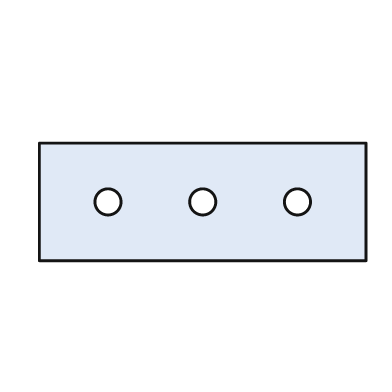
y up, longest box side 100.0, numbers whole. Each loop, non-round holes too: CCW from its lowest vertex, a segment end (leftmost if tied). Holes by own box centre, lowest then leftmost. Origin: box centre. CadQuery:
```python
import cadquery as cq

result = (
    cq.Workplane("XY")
    .moveTo(-50.0, -18.0)
    .lineTo(50.0, -18.0)
    .lineTo(50.0, 18.0)
    .lineTo(-50.0, 18.0)
    .close()
    .moveTo(-29.0, 0.0)
    .circle(4.0)
    .moveTo(0.0, 0.0)
    .circle(4.0)
    .moveTo(29.0, 0.0)
    .circle(4.0)
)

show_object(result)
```